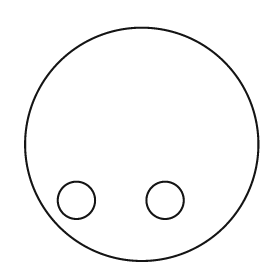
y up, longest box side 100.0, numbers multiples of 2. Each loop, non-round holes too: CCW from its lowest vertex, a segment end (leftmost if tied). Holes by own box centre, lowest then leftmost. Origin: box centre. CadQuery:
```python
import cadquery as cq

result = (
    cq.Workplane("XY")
    .moveTo(0.0, 0.0)
    .circle(50.0)
    .moveTo(-28.0, -24.0)
    .circle(8.0)
    .moveTo(10.0, -24.0)
    .circle(8.0)
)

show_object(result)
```